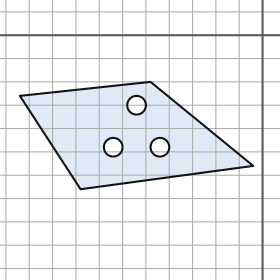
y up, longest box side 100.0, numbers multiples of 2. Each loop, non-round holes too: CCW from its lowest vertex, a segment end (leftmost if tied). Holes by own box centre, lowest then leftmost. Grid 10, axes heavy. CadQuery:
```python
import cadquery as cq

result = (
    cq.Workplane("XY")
    .moveTo(-78.0, -66.0)
    .lineTo(-4.0, -56.0)
    .lineTo(-48.0, -20.0)
    .lineTo(-104.0, -26.0)
    .close()
    .moveTo(-64.0, -48.0)
    .circle(4.0)
    .moveTo(-44.0, -48.0)
    .circle(4.0)
    .moveTo(-54.0, -30.0)
    .circle(4.0)
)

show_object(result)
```